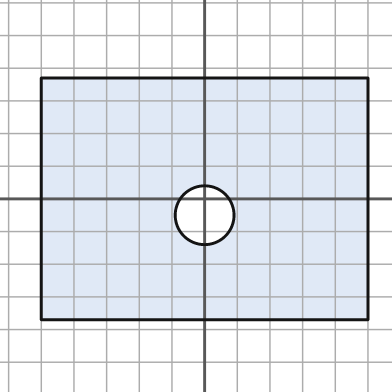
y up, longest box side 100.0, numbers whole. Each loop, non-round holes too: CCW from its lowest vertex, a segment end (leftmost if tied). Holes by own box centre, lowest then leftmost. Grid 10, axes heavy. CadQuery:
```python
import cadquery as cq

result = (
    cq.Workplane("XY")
    .moveTo(-50.0, -37.0)
    .lineTo(50.0, -37.0)
    .lineTo(50.0, 37.0)
    .lineTo(-50.0, 37.0)
    .close()
    .moveTo(0.0, -5.0)
    .circle(9.0)
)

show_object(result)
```